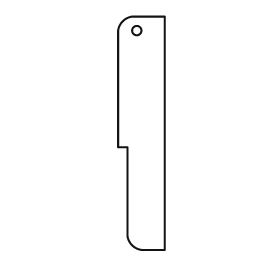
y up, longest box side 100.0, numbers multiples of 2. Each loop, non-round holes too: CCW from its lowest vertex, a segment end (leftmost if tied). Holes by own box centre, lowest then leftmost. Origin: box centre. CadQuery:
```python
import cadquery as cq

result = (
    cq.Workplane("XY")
    .moveTo(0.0, -50.0)
    .lineTo(10.0, -50.0)
    .lineTo(10.0, 50.0)
    .lineTo(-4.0, 50.0)
    .threePointArc((-8.0, 48.0), (-10.0, 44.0))
    .lineTo(-10.0, -6.0)
    .lineTo(-6.0, -6.0)
    .lineTo(-6.0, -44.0)
    .threePointArc((-4.0, -48.0), (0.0, -50.0))
    .close()
    .moveTo(-2.0, 44.0)
    .circle(2.0)
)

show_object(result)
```